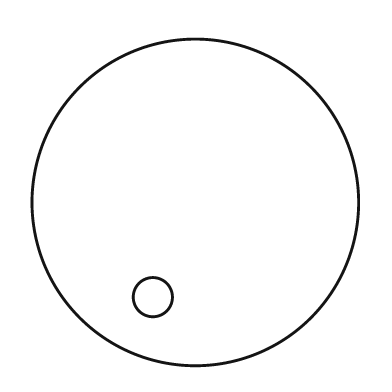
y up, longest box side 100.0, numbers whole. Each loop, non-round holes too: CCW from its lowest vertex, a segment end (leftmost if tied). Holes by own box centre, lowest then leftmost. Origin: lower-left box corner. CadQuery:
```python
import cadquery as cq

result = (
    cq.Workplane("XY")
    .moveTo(50.0, 50.0)
    .circle(50.0)
    .moveTo(37.0, 21.0)
    .circle(6.0)
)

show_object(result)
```